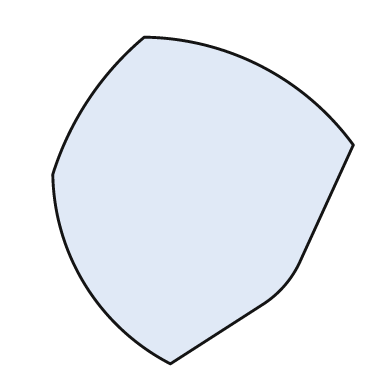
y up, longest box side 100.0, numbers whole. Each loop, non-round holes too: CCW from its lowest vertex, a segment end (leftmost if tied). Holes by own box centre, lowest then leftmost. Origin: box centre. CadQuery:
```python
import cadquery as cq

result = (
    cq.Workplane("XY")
    .moveTo(-10.0, -50.0)
    .lineTo(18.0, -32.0)
    .threePointArc((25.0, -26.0), (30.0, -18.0))
    .lineTo(46.0, 17.0)
    .threePointArc((18.0, 41.0), (-18.0, 50.0))
    .threePointArc((-35.0, 31.0), (-46.0, 8.0))
    .threePointArc((-36.0, -26.0), (-10.0, -50.0))
    .close()
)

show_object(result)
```